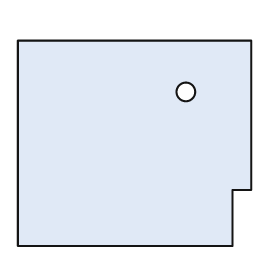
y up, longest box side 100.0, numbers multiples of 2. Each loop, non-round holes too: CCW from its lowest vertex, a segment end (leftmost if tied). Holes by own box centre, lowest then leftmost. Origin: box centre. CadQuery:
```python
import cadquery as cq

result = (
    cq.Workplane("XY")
    .moveTo(-50.0, -44.0)
    .lineTo(42.0, -44.0)
    .lineTo(42.0, -20.0)
    .lineTo(50.0, -20.0)
    .lineTo(50.0, 44.0)
    .lineTo(-50.0, 44.0)
    .close()
    .moveTo(22.0, 22.0)
    .circle(4.0)
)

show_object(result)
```